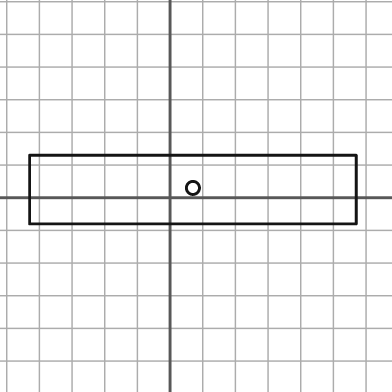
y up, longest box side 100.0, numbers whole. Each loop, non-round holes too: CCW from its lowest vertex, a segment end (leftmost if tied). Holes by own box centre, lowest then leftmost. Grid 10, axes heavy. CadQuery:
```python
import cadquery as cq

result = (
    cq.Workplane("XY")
    .moveTo(-43.0, -8.0)
    .lineTo(57.0, -8.0)
    .lineTo(57.0, 13.0)
    .lineTo(-43.0, 13.0)
    .close()
    .moveTo(7.0, 3.0)
    .circle(2.0)
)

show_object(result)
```